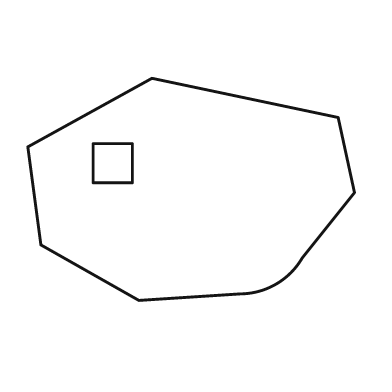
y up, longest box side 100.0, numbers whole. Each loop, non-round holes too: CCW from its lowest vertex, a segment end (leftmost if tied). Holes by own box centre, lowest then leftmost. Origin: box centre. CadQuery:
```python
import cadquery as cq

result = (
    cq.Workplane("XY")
    .moveTo(-16.0, -34.0)
    .lineTo(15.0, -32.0)
    .threePointArc((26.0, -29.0), (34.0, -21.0))
    .lineTo(50.0, -1.0)
    .lineTo(45.0, 22.0)
    .lineTo(-12.0, 34.0)
    .lineTo(-50.0, 13.0)
    .lineTo(-46.0, -17.0)
    .close()
    .moveTo(-30.0, 2.0)
    .lineTo(-18.0, 2.0)
    .lineTo(-18.0, 14.0)
    .lineTo(-30.0, 14.0)
    .close()
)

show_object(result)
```